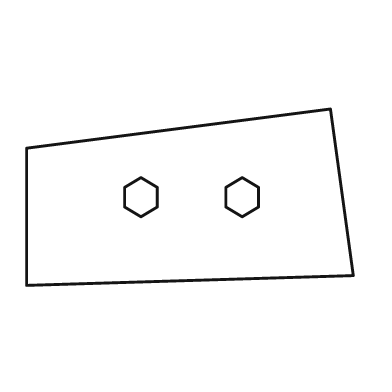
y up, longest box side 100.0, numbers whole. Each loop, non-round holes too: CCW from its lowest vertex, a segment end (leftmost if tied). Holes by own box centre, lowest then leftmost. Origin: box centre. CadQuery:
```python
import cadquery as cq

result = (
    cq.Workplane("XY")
    .moveTo(-50.0, -27.0)
    .lineTo(50.0, -24.0)
    .lineTo(43.0, 27.0)
    .lineTo(-50.0, 15.0)
    .close()
    .moveTo(-15.0, -6.0)
    .lineTo(-10.0, -3.0)
    .lineTo(-10.0, 3.0)
    .lineTo(-15.0, 6.0)
    .lineTo(-20.0, 3.0)
    .lineTo(-20.0, -3.0)
    .close()
    .moveTo(16.0, -6.0)
    .lineTo(21.0, -3.0)
    .lineTo(21.0, 3.0)
    .lineTo(16.0, 6.0)
    .lineTo(11.0, 3.0)
    .lineTo(11.0, -3.0)
    .close()
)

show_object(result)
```